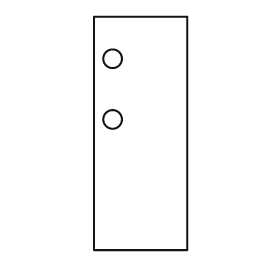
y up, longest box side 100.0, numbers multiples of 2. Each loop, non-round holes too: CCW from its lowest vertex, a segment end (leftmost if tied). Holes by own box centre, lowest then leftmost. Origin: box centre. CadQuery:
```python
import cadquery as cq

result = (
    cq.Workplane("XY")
    .moveTo(-20.0, -50.0)
    .lineTo(20.0, -50.0)
    .lineTo(20.0, 50.0)
    .lineTo(-20.0, 50.0)
    .close()
    .moveTo(-12.0, 6.0)
    .circle(4.0)
    .moveTo(-12.0, 32.0)
    .circle(4.0)
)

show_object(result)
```